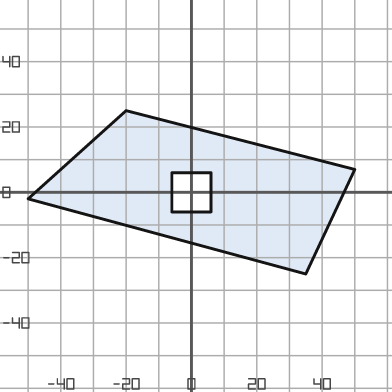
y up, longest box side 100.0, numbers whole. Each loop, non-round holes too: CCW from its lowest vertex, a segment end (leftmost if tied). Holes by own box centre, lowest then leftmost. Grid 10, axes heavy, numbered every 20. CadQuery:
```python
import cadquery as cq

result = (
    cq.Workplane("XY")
    .moveTo(35.0, -25.0)
    .lineTo(50.0, 7.0)
    .lineTo(-20.0, 25.0)
    .lineTo(-50.0, -2.0)
    .close()
    .moveTo(-6.0, -6.0)
    .lineTo(6.0, -6.0)
    .lineTo(6.0, 6.0)
    .lineTo(-6.0, 6.0)
    .close()
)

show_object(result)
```